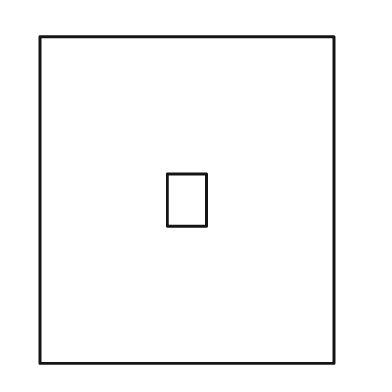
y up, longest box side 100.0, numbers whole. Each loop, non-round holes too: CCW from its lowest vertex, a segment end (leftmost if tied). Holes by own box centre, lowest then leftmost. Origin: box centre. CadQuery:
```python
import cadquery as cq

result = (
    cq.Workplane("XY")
    .moveTo(-45.0, -50.0)
    .lineTo(45.0, -50.0)
    .lineTo(45.0, 50.0)
    .lineTo(-45.0, 50.0)
    .close()
    .moveTo(-6.0, -8.0)
    .lineTo(6.0, -8.0)
    .lineTo(6.0, 8.0)
    .lineTo(-6.0, 8.0)
    .close()
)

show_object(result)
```